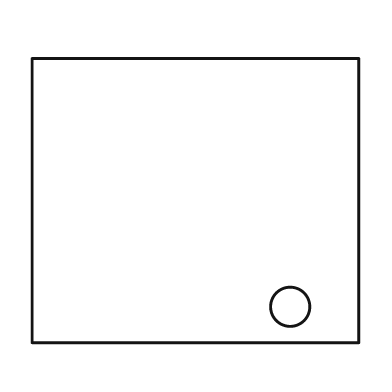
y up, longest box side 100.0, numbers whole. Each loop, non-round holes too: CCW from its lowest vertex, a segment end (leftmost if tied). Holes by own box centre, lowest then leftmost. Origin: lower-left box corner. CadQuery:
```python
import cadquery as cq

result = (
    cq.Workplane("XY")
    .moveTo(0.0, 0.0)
    .lineTo(100.0, 0.0)
    .lineTo(100.0, 87.0)
    .lineTo(0.0, 87.0)
    .close()
    .moveTo(79.0, 11.0)
    .circle(6.0)
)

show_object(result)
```